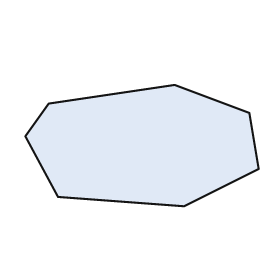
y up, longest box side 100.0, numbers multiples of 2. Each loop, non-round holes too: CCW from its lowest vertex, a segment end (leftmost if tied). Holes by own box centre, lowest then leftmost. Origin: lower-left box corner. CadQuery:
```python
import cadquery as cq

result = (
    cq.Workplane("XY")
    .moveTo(68.0, 0.0)
    .lineTo(100.0, 16.0)
    .lineTo(96.0, 40.0)
    .lineTo(64.0, 52.0)
    .lineTo(10.0, 44.0)
    .lineTo(0.0, 30.0)
    .lineTo(14.0, 4.0)
    .close()
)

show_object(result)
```